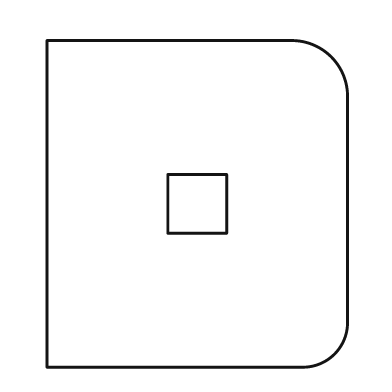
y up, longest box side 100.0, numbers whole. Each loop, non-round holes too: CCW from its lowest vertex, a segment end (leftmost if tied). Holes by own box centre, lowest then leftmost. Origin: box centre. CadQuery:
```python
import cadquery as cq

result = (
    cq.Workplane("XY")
    .moveTo(-46.0, -50.0)
    .lineTo(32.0, -50.0)
    .threePointArc((42.0, -46.0), (46.0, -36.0))
    .lineTo(46.0, 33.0)
    .threePointArc((41.0, 45.0), (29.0, 50.0))
    .lineTo(-46.0, 50.0)
    .close()
    .moveTo(-9.0, -9.0)
    .lineTo(9.0, -9.0)
    .lineTo(9.0, 9.0)
    .lineTo(-9.0, 9.0)
    .close()
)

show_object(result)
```